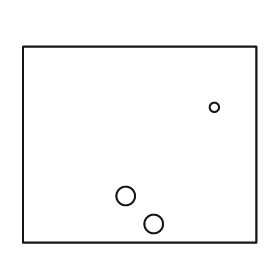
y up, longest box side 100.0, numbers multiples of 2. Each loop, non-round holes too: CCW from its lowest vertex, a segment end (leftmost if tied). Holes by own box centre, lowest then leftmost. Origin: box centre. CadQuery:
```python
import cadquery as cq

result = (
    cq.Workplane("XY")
    .moveTo(-50.0, -42.0)
    .lineTo(50.0, -42.0)
    .lineTo(50.0, 42.0)
    .lineTo(-50.0, 42.0)
    .close()
    .moveTo(6.0, -34.0)
    .circle(4.0)
    .moveTo(-6.0, -22.0)
    .circle(4.0)
    .moveTo(32.0, 16.0)
    .circle(2.0)
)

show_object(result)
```